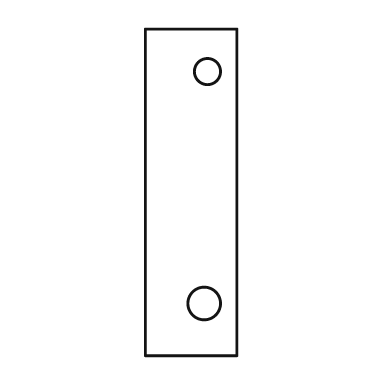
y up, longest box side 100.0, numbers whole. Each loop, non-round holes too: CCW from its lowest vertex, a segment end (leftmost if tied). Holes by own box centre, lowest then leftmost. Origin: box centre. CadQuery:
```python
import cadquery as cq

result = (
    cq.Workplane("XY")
    .moveTo(-14.0, -50.0)
    .lineTo(14.0, -50.0)
    .lineTo(14.0, 50.0)
    .lineTo(-14.0, 50.0)
    .close()
    .moveTo(4.0, -34.0)
    .circle(5.0)
    .moveTo(5.0, 37.0)
    .circle(4.0)
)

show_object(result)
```